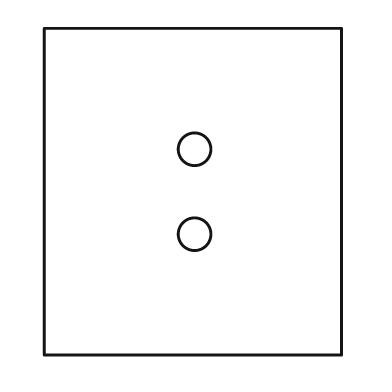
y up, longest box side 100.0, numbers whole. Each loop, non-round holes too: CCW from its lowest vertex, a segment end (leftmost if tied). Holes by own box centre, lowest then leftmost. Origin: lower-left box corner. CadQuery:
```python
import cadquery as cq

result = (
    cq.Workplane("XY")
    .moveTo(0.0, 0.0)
    .lineTo(91.0, 0.0)
    .lineTo(91.0, 100.0)
    .lineTo(0.0, 100.0)
    .close()
    .moveTo(46.0, 37.0)
    .circle(5.0)
    .moveTo(46.0, 63.0)
    .circle(5.0)
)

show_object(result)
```